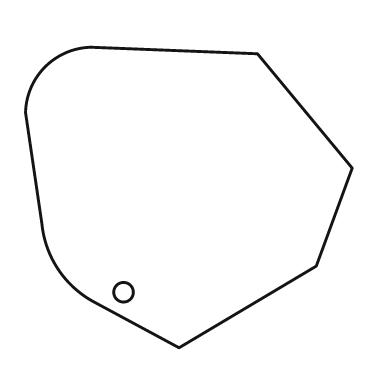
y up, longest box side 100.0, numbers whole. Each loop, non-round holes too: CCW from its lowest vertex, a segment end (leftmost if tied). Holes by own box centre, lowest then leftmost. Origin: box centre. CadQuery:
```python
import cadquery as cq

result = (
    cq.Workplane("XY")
    .moveTo(-3.0, -46.0)
    .lineTo(39.0, -21.0)
    .lineTo(50.0, 9.0)
    .lineTo(21.0, 44.0)
    .lineTo(-30.0, 46.0)
    .threePointArc((-44.0, 40.0), (-50.0, 26.0))
    .lineTo(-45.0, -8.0)
    .threePointArc((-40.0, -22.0), (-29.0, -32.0))
    .close()
    .moveTo(-20.0, -29.0)
    .circle(3.0)
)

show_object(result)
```